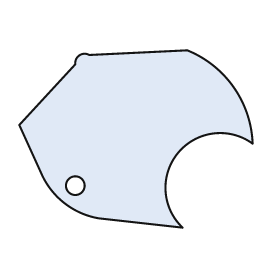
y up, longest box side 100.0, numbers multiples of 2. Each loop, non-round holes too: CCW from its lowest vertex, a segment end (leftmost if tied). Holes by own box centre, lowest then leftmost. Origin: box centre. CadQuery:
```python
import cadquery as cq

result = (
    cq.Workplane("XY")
    .moveTo(20.0, -38.0)
    .threePointArc((18.0, -6.0), (50.0, -2.0))
    .threePointArc((42.0, 22.0), (22.0, 38.0))
    .lineTo(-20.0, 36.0)
    .threePointArc((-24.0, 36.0), (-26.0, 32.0))
    .lineTo(-50.0, 6.0)
    .lineTo(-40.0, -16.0)
    .threePointArc((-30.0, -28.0), (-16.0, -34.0))
    .close()
    .moveTo(-26.0, -20.0)
    .circle(4.0)
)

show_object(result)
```